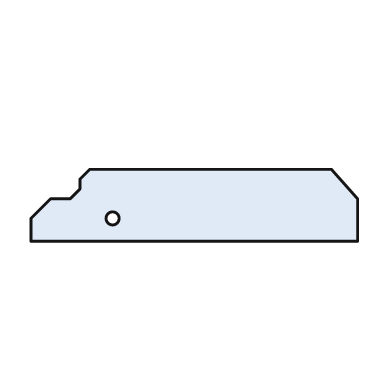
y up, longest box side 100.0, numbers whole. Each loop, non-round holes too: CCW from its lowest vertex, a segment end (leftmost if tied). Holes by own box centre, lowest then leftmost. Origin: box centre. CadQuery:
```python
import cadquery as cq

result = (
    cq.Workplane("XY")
    .moveTo(-50.0, -11.0)
    .lineTo(50.0, -11.0)
    .lineTo(50.0, 2.0)
    .lineTo(42.0, 11.0)
    .lineTo(-32.0, 11.0)
    .lineTo(-35.0, 8.0)
    .lineTo(-35.0, 5.0)
    .lineTo(-38.0, 2.0)
    .lineTo(-44.0, 2.0)
    .lineTo(-50.0, -4.0)
    .close()
    .moveTo(-25.0, -4.0)
    .circle(2.0)
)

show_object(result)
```